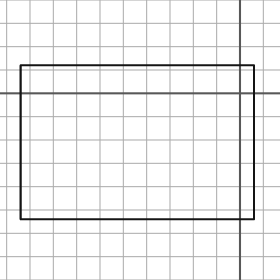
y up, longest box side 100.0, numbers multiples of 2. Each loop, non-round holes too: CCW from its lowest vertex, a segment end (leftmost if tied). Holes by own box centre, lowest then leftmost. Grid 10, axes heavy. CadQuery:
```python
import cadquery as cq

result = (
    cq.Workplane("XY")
    .moveTo(-94.0, -54.0)
    .lineTo(6.0, -54.0)
    .lineTo(6.0, 12.0)
    .lineTo(-94.0, 12.0)
    .close()
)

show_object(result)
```